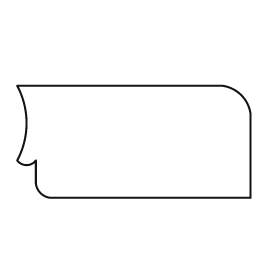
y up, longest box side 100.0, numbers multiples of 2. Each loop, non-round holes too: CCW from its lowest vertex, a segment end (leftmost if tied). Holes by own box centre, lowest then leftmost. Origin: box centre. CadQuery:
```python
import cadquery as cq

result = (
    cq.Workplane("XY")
    .moveTo(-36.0, -24.0)
    .lineTo(50.0, -24.0)
    .lineTo(50.0, 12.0)
    .threePointArc((46.0, 20.0), (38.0, 24.0))
    .lineTo(-50.0, 24.0)
    .threePointArc((-46.0, 8.0), (-50.0, -8.0))
    .threePointArc((-46.0, -10.0), (-42.0, -8.0))
    .lineTo(-42.0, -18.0)
    .threePointArc((-40.0, -22.0), (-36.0, -24.0))
    .close()
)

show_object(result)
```